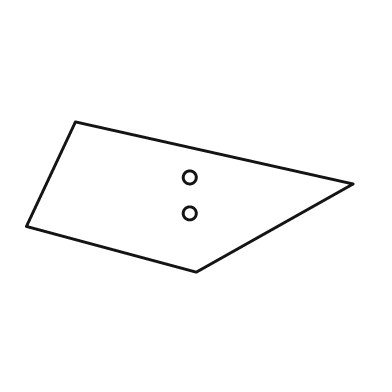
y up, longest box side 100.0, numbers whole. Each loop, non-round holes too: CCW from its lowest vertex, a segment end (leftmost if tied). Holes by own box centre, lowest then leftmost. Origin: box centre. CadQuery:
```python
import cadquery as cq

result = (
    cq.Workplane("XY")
    .moveTo(2.0, -23.0)
    .lineTo(50.0, 4.0)
    .lineTo(-35.0, 23.0)
    .lineTo(-50.0, -9.0)
    .close()
    .moveTo(0.0, -5.0)
    .circle(2.0)
    .moveTo(0.0, 6.0)
    .circle(2.0)
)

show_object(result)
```